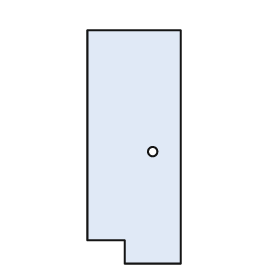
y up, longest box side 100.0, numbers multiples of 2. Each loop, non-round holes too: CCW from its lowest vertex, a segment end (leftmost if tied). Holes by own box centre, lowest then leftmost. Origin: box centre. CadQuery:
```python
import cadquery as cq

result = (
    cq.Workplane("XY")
    .moveTo(-4.0, -50.0)
    .lineTo(20.0, -50.0)
    .lineTo(20.0, 50.0)
    .lineTo(-20.0, 50.0)
    .lineTo(-20.0, -40.0)
    .lineTo(-4.0, -40.0)
    .close()
    .moveTo(8.0, -2.0)
    .circle(2.0)
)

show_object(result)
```